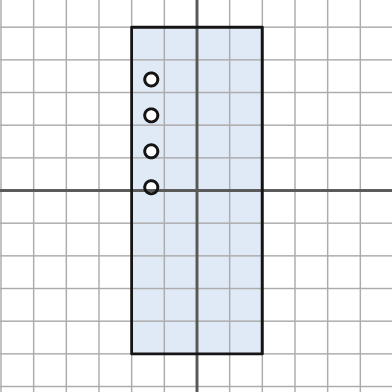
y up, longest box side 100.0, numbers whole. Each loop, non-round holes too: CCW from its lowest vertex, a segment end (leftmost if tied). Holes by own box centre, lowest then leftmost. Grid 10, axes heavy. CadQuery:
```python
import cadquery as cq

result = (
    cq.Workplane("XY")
    .moveTo(-20.0, -50.0)
    .lineTo(20.0, -50.0)
    .lineTo(20.0, 50.0)
    .lineTo(-20.0, 50.0)
    .close()
    .moveTo(-14.0, 1.0)
    .circle(2.0)
    .moveTo(-14.0, 12.0)
    .circle(2.0)
    .moveTo(-14.0, 23.0)
    .circle(2.0)
    .moveTo(-14.0, 34.0)
    .circle(2.0)
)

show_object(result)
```